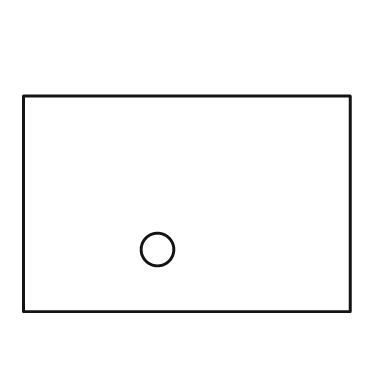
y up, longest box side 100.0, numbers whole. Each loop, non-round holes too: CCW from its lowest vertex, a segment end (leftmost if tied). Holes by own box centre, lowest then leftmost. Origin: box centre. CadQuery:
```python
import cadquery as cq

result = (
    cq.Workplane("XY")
    .moveTo(-50.0, -33.0)
    .lineTo(50.0, -33.0)
    .lineTo(50.0, 33.0)
    .lineTo(-50.0, 33.0)
    .close()
    .moveTo(-9.0, -14.0)
    .circle(5.0)
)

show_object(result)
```